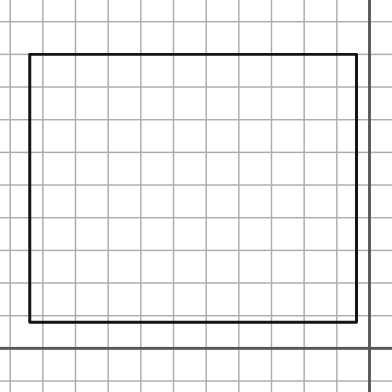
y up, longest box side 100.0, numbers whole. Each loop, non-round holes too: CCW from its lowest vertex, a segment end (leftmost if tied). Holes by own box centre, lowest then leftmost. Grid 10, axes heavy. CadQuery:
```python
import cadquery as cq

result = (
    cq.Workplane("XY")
    .moveTo(-104.0, 8.0)
    .lineTo(-4.0, 8.0)
    .lineTo(-4.0, 90.0)
    .lineTo(-104.0, 90.0)
    .close()
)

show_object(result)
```